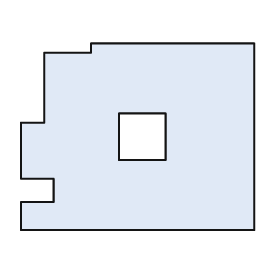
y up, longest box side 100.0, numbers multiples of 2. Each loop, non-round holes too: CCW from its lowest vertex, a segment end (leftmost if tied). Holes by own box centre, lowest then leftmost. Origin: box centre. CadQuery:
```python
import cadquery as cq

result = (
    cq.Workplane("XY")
    .moveTo(-50.0, -40.0)
    .lineTo(50.0, -40.0)
    .lineTo(50.0, 40.0)
    .lineTo(-20.0, 40.0)
    .lineTo(-20.0, 36.0)
    .lineTo(-40.0, 36.0)
    .lineTo(-40.0, 6.0)
    .lineTo(-50.0, 6.0)
    .lineTo(-50.0, -18.0)
    .lineTo(-36.0, -18.0)
    .lineTo(-36.0, -28.0)
    .lineTo(-50.0, -28.0)
    .close()
    .moveTo(-8.0, -10.0)
    .lineTo(12.0, -10.0)
    .lineTo(12.0, 10.0)
    .lineTo(-8.0, 10.0)
    .close()
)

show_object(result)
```